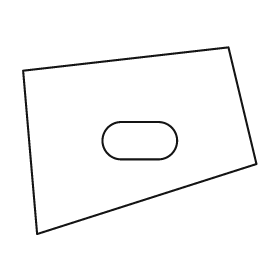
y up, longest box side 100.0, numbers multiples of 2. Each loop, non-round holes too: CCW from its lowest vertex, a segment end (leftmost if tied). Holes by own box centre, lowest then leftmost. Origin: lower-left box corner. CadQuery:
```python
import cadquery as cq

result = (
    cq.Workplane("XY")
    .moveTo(6.0, 0.0)
    .lineTo(100.0, 30.0)
    .lineTo(88.0, 80.0)
    .lineTo(0.0, 70.0)
    .close()
    .moveTo(42.0, 32.0)
    .lineTo(58.0, 32.0)
    .threePointArc((66.0, 40.0), (58.0, 48.0))
    .lineTo(42.0, 48.0)
    .threePointArc((34.0, 40.0), (42.0, 32.0))
    .close()
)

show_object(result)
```